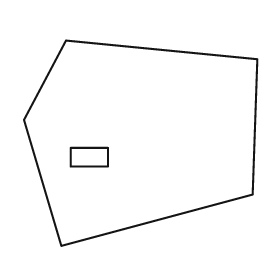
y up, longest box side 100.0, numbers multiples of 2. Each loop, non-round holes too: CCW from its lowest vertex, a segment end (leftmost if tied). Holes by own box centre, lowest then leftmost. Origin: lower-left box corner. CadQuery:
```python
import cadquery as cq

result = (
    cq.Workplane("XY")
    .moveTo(16.0, 0.0)
    .lineTo(98.0, 22.0)
    .lineTo(100.0, 80.0)
    .lineTo(18.0, 88.0)
    .lineTo(0.0, 54.0)
    .close()
    .moveTo(20.0, 34.0)
    .lineTo(36.0, 34.0)
    .lineTo(36.0, 42.0)
    .lineTo(20.0, 42.0)
    .close()
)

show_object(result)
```